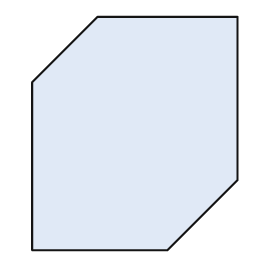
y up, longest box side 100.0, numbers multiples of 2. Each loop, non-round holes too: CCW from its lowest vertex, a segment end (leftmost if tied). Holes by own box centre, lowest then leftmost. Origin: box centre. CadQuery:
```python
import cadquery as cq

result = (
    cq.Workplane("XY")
    .moveTo(-44.0, -50.0)
    .lineTo(14.0, -50.0)
    .lineTo(44.0, -20.0)
    .lineTo(44.0, 50.0)
    .lineTo(-16.0, 50.0)
    .lineTo(-44.0, 22.0)
    .close()
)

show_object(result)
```